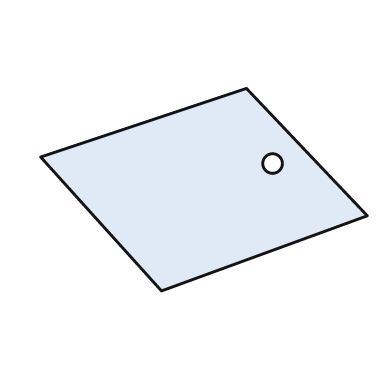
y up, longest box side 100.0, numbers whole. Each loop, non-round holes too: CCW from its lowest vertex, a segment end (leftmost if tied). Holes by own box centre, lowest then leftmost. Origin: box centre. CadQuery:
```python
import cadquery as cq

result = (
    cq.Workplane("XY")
    .moveTo(-13.0, -31.0)
    .lineTo(50.0, -8.0)
    .lineTo(13.0, 31.0)
    .lineTo(-50.0, 10.0)
    .close()
    .moveTo(21.0, 8.0)
    .circle(3.0)
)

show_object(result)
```